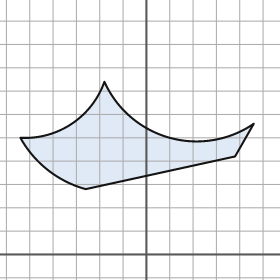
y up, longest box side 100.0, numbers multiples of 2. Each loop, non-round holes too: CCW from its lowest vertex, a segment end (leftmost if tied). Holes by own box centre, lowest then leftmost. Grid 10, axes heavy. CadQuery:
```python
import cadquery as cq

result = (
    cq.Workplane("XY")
    .moveTo(-26.0, 28.0)
    .lineTo(38.0, 42.0)
    .lineTo(46.0, 56.0)
    .threePointArc((10.0, 50.0), (-18.0, 74.0))
    .threePointArc((-32.0, 56.0), (-54.0, 50.0))
    .threePointArc((-42.0, 36.0), (-26.0, 28.0))
    .close()
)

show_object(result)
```